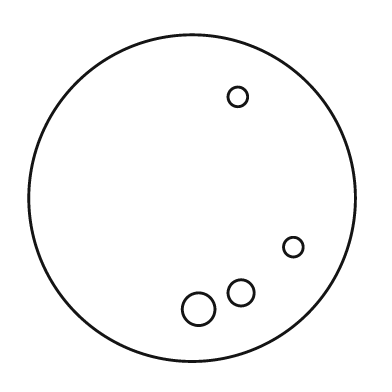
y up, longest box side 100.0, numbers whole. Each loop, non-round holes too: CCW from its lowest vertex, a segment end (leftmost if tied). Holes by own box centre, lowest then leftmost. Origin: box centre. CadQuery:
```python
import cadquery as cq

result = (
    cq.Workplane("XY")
    .moveTo(0.0, 0.0)
    .circle(50.0)
    .moveTo(2.0, -34.0)
    .circle(5.0)
    .moveTo(15.0, -29.0)
    .circle(4.0)
    .moveTo(31.0, -15.0)
    .circle(3.0)
    .moveTo(14.0, 31.0)
    .circle(3.0)
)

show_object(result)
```